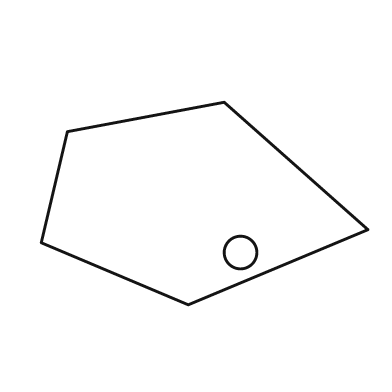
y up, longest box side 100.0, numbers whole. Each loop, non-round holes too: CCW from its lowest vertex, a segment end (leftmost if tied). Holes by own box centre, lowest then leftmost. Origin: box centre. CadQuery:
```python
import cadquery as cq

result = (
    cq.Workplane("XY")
    .moveTo(-5.0, -31.0)
    .lineTo(50.0, -8.0)
    .lineTo(6.0, 31.0)
    .lineTo(-42.0, 22.0)
    .lineTo(-50.0, -12.0)
    .close()
    .moveTo(11.0, -15.0)
    .circle(5.0)
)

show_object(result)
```